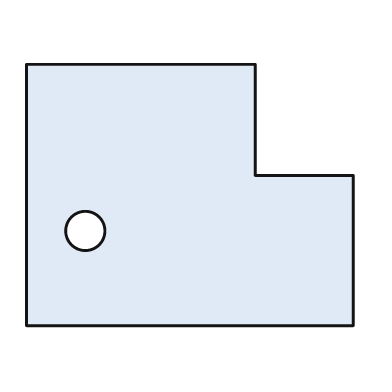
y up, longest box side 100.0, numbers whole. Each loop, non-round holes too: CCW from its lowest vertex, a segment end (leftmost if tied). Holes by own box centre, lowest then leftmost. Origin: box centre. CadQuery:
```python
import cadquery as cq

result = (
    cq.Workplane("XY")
    .moveTo(-50.0, -40.0)
    .lineTo(50.0, -40.0)
    .lineTo(50.0, 6.0)
    .lineTo(20.0, 6.0)
    .lineTo(20.0, 40.0)
    .lineTo(-50.0, 40.0)
    .close()
    .moveTo(-32.0, -11.0)
    .circle(6.0)
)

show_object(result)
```